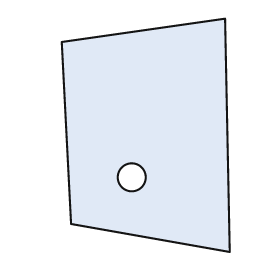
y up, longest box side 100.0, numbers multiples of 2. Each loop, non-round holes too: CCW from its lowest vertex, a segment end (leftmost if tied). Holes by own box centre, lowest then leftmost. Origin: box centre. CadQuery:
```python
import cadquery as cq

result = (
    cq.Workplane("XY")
    .moveTo(36.0, -50.0)
    .lineTo(34.0, 50.0)
    .lineTo(-36.0, 40.0)
    .lineTo(-32.0, -38.0)
    .close()
    .moveTo(-6.0, -18.0)
    .circle(6.0)
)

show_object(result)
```